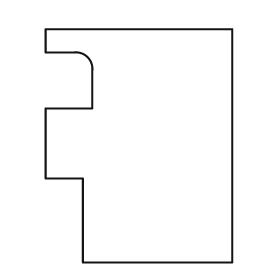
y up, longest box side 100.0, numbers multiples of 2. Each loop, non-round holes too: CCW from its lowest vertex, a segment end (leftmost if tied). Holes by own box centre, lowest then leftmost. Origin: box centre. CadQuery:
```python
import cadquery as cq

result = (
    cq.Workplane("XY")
    .moveTo(-24.0, -50.0)
    .lineTo(40.0, -50.0)
    .lineTo(40.0, 50.0)
    .lineTo(-40.0, 50.0)
    .lineTo(-40.0, 40.0)
    .lineTo(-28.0, 40.0)
    .threePointArc((-22.0, 38.0), (-20.0, 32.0))
    .lineTo(-20.0, 16.0)
    .lineTo(-40.0, 16.0)
    .lineTo(-40.0, -14.0)
    .lineTo(-24.0, -14.0)
    .close()
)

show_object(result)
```